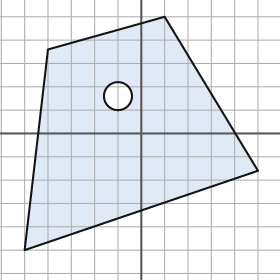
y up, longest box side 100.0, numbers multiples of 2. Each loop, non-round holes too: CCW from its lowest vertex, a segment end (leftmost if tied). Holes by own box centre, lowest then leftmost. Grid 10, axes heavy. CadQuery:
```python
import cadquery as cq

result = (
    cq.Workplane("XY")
    .moveTo(-50.0, -50.0)
    .lineTo(50.0, -16.0)
    .lineTo(10.0, 50.0)
    .lineTo(-40.0, 36.0)
    .close()
    .moveTo(-10.0, 16.0)
    .circle(6.0)
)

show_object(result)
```